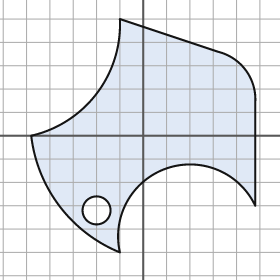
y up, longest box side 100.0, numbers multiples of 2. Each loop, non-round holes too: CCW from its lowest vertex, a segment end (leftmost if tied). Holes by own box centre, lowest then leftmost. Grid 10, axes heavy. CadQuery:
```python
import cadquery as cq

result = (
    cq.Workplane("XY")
    .moveTo(-10.0, -50.0)
    .threePointArc((10.0, -14.0), (48.0, -30.0))
    .lineTo(48.0, 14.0)
    .threePointArc((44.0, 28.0), (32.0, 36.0))
    .lineTo(-10.0, 50.0)
    .threePointArc((-20.0, 18.0), (-48.0, 0.0))
    .threePointArc((-36.0, -30.0), (-10.0, -50.0))
    .close()
    .moveTo(-20.0, -32.0)
    .circle(6.0)
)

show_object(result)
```